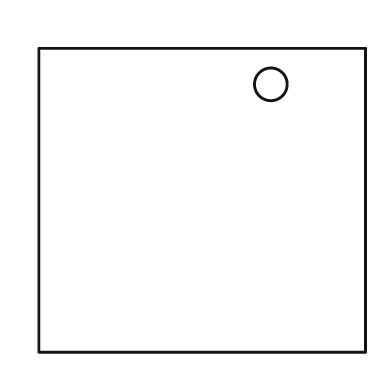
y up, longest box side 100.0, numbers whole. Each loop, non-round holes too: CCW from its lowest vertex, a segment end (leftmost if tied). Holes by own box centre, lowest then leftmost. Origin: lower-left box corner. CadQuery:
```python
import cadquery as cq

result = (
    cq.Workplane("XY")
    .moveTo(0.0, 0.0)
    .lineTo(100.0, 0.0)
    .lineTo(100.0, 93.0)
    .lineTo(0.0, 93.0)
    .close()
    .moveTo(71.0, 82.0)
    .circle(5.0)
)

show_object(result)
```